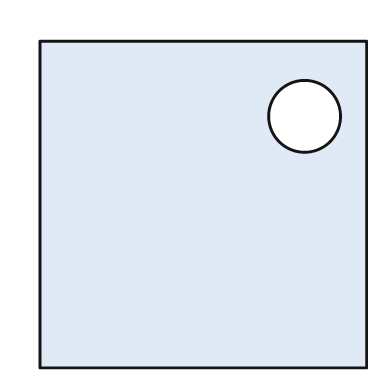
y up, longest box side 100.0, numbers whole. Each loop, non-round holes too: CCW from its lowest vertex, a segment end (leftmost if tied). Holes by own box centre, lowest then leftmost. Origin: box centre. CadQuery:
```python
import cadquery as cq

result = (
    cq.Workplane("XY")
    .moveTo(-50.0, -50.0)
    .lineTo(50.0, -50.0)
    .lineTo(50.0, 50.0)
    .lineTo(-50.0, 50.0)
    .close()
    .moveTo(31.0, 27.0)
    .circle(11.0)
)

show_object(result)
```